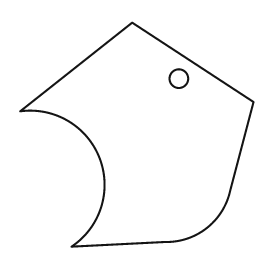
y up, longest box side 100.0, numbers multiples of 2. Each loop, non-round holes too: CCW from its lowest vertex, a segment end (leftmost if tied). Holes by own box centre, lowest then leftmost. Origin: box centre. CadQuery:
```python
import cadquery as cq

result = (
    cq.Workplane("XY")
    .moveTo(-28.0, -48.0)
    .lineTo(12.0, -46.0)
    .threePointArc((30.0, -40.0), (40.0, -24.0))
    .lineTo(50.0, 14.0)
    .lineTo(-2.0, 48.0)
    .lineTo(-50.0, 10.0)
    .threePointArc((-16.0, -10.0), (-28.0, -48.0))
    .close()
    .moveTo(18.0, 24.0)
    .circle(4.0)
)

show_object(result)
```